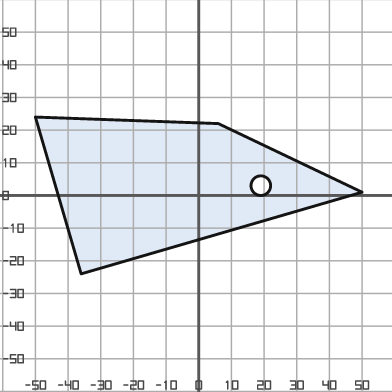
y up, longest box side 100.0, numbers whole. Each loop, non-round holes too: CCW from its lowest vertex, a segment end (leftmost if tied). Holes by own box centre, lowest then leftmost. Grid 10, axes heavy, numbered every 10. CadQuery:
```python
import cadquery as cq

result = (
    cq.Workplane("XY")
    .moveTo(-36.0, -24.0)
    .lineTo(50.0, 1.0)
    .lineTo(6.0, 22.0)
    .lineTo(-50.0, 24.0)
    .close()
    .moveTo(19.0, 3.0)
    .circle(3.0)
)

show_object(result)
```